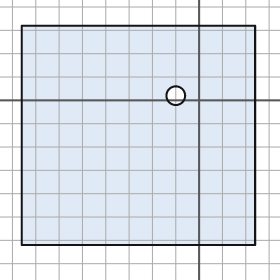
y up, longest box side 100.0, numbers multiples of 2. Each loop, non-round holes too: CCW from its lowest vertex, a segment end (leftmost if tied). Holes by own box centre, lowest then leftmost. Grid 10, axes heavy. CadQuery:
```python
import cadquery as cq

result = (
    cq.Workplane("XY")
    .moveTo(-76.0, -62.0)
    .lineTo(24.0, -62.0)
    .lineTo(24.0, 32.0)
    .lineTo(-76.0, 32.0)
    .close()
    .moveTo(-10.0, 2.0)
    .circle(4.0)
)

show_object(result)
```